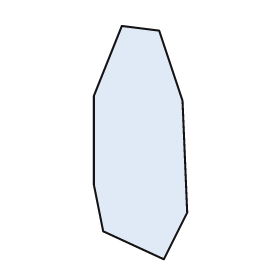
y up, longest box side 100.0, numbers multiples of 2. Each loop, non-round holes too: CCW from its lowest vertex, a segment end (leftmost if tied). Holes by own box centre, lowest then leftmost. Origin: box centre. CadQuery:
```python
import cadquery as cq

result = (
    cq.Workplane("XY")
    .moveTo(10.0, -50.0)
    .lineTo(20.0, -30.0)
    .lineTo(18.0, 18.0)
    .lineTo(8.0, 48.0)
    .lineTo(-8.0, 50.0)
    .lineTo(-20.0, 20.0)
    .lineTo(-20.0, -18.0)
    .lineTo(-16.0, -38.0)
    .close()
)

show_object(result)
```